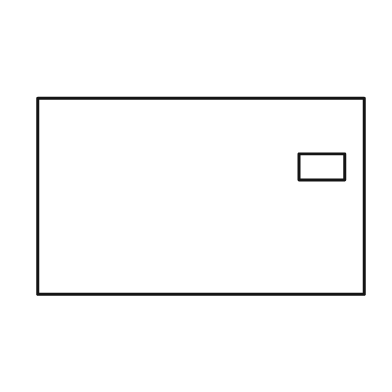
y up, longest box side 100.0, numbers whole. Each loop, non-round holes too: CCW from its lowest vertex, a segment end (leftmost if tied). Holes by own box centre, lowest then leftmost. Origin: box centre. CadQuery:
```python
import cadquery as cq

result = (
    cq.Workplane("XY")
    .moveTo(-50.0, -30.0)
    .lineTo(50.0, -30.0)
    .lineTo(50.0, 30.0)
    .lineTo(-50.0, 30.0)
    .close()
    .moveTo(30.0, 5.0)
    .lineTo(44.0, 5.0)
    .lineTo(44.0, 13.0)
    .lineTo(30.0, 13.0)
    .close()
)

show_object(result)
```